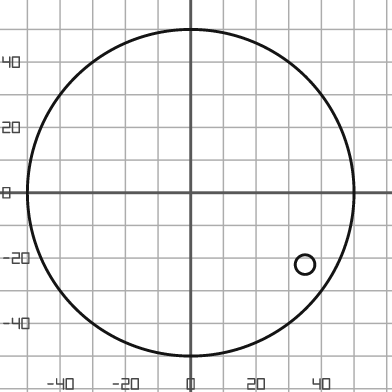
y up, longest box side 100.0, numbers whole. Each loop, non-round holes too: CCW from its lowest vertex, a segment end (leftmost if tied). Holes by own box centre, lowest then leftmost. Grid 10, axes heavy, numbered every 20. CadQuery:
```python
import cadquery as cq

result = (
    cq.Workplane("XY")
    .moveTo(0.0, 0.0)
    .circle(50.0)
    .moveTo(35.0, -22.0)
    .circle(3.0)
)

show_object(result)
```